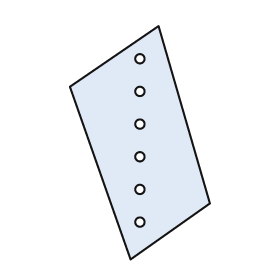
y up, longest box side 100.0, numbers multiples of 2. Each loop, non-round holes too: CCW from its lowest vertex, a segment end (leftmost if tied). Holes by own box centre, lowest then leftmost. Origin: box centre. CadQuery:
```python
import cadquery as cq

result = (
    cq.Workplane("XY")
    .moveTo(-4.0, -50.0)
    .lineTo(30.0, -26.0)
    .lineTo(8.0, 50.0)
    .lineTo(-30.0, 24.0)
    .close()
    .moveTo(0.0, -34.0)
    .circle(2.0)
    .moveTo(0.0, -20.0)
    .circle(2.0)
    .moveTo(0.0, -6.0)
    .circle(2.0)
    .moveTo(0.0, 8.0)
    .circle(2.0)
    .moveTo(0.0, 22.0)
    .circle(2.0)
    .moveTo(0.0, 36.0)
    .circle(2.0)
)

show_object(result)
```